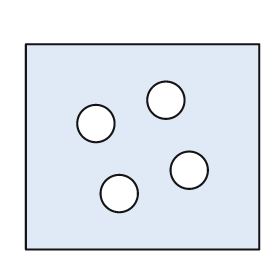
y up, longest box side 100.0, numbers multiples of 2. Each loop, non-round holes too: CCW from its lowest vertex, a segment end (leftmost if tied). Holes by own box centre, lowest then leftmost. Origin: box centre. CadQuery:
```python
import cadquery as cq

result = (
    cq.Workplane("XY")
    .moveTo(-50.0, -44.0)
    .lineTo(50.0, -44.0)
    .lineTo(50.0, 44.0)
    .lineTo(-50.0, 44.0)
    .close()
    .moveTo(-10.0, -20.0)
    .circle(8.0)
    .moveTo(20.0, -10.0)
    .circle(8.0)
    .moveTo(-20.0, 10.0)
    .circle(8.0)
    .moveTo(10.0, 20.0)
    .circle(8.0)
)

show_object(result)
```